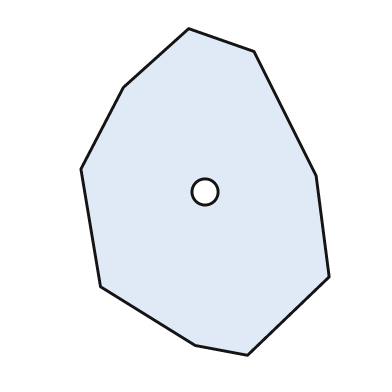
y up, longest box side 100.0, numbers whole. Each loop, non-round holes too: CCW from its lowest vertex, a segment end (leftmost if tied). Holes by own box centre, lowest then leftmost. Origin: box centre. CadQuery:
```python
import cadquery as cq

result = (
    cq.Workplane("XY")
    .moveTo(13.0, -50.0)
    .lineTo(38.0, -26.0)
    .lineTo(34.0, 5.0)
    .lineTo(15.0, 43.0)
    .lineTo(-5.0, 50.0)
    .lineTo(-25.0, 32.0)
    .lineTo(-38.0, 7.0)
    .lineTo(-32.0, -29.0)
    .lineTo(-3.0, -47.0)
    .close()
    .moveTo(0.0, 0.0)
    .circle(4.0)
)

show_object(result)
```